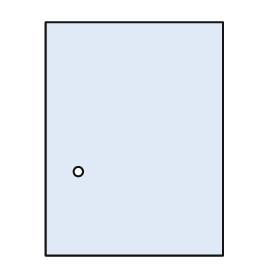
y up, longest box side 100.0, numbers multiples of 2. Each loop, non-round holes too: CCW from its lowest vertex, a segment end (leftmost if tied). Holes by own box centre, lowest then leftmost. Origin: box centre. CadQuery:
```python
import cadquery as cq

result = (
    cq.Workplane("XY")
    .moveTo(-38.0, -50.0)
    .lineTo(38.0, -50.0)
    .lineTo(38.0, 50.0)
    .lineTo(-38.0, 50.0)
    .close()
    .moveTo(-24.0, -14.0)
    .circle(2.0)
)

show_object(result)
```